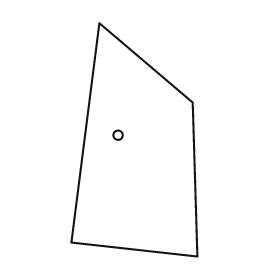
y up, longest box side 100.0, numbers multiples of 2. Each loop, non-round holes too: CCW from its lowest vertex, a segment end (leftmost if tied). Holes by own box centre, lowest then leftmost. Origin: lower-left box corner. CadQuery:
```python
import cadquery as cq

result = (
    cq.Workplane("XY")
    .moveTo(54.0, 0.0)
    .lineTo(52.0, 66.0)
    .lineTo(12.0, 100.0)
    .lineTo(0.0, 6.0)
    .close()
    .moveTo(20.0, 52.0)
    .circle(2.0)
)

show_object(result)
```